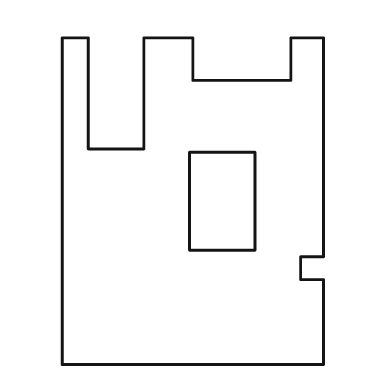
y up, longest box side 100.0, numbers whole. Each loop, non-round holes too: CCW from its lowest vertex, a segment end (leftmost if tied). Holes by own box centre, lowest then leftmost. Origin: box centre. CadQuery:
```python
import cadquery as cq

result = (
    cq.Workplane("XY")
    .moveTo(-40.0, -50.0)
    .lineTo(40.0, -50.0)
    .lineTo(40.0, -24.0)
    .lineTo(33.0, -24.0)
    .lineTo(33.0, -17.0)
    .lineTo(40.0, -17.0)
    .lineTo(40.0, 50.0)
    .lineTo(30.0, 50.0)
    .lineTo(30.0, 37.0)
    .lineTo(0.0, 37.0)
    .lineTo(0.0, 50.0)
    .lineTo(-15.0, 50.0)
    .lineTo(-15.0, 16.0)
    .lineTo(-32.0, 16.0)
    .lineTo(-32.0, 50.0)
    .lineTo(-40.0, 50.0)
    .close()
    .moveTo(-1.0, -15.0)
    .lineTo(19.0, -15.0)
    .lineTo(19.0, 15.0)
    .lineTo(-1.0, 15.0)
    .close()
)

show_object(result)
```